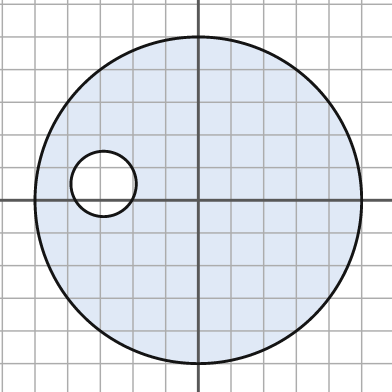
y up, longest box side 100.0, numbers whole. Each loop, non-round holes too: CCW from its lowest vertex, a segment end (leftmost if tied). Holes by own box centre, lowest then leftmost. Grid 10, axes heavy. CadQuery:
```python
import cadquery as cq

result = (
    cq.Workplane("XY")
    .moveTo(0.0, 0.0)
    .circle(50.0)
    .moveTo(-29.0, 5.0)
    .circle(10.0)
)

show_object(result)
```